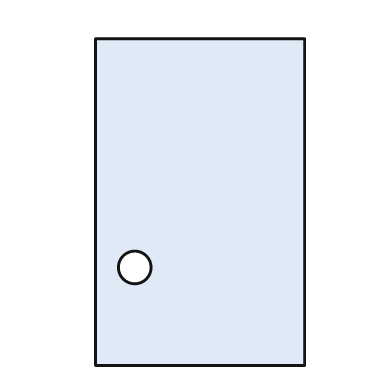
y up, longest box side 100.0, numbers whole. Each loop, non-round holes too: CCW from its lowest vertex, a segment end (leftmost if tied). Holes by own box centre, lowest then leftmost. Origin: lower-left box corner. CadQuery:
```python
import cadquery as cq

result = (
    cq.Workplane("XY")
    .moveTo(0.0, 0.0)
    .lineTo(64.0, 0.0)
    .lineTo(64.0, 100.0)
    .lineTo(0.0, 100.0)
    .close()
    .moveTo(12.0, 30.0)
    .circle(5.0)
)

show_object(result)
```